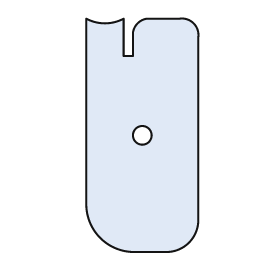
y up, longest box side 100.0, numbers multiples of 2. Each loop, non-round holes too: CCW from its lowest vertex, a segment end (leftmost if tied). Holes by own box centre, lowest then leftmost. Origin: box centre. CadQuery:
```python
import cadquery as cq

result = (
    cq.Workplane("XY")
    .moveTo(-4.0, -50.0)
    .lineTo(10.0, -50.0)
    .threePointArc((20.0, -46.0), (24.0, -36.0))
    .lineTo(24.0, 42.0)
    .threePointArc((22.0, 48.0), (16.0, 50.0))
    .lineTo(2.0, 50.0)
    .threePointArc((-2.0, 48.0), (-4.0, 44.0))
    .lineTo(-4.0, 34.0)
    .lineTo(-8.0, 34.0)
    .lineTo(-8.0, 50.0)
    .threePointArc((-16.0, 48.0), (-24.0, 50.0))
    .lineTo(-24.0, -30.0)
    .threePointArc((-18.0, -44.0), (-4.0, -50.0))
    .close()
    .moveTo(0.0, 0.0)
    .circle(4.0)
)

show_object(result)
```